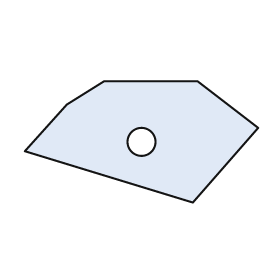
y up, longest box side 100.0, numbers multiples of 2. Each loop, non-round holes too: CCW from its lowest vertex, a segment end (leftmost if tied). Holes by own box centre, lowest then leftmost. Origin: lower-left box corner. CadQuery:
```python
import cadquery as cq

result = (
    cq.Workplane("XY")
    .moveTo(72.0, 0.0)
    .lineTo(100.0, 32.0)
    .lineTo(74.0, 52.0)
    .lineTo(34.0, 52.0)
    .lineTo(18.0, 42.0)
    .lineTo(0.0, 22.0)
    .close()
    .moveTo(50.0, 26.0)
    .circle(6.0)
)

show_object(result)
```